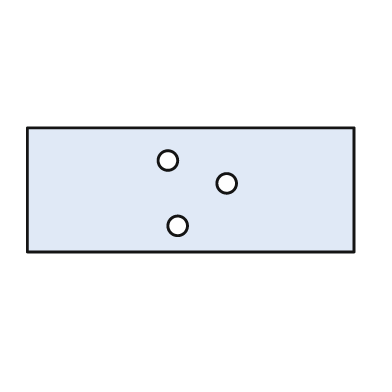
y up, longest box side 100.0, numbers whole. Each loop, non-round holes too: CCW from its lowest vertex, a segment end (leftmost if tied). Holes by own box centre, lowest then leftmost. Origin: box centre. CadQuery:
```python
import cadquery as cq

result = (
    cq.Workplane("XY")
    .moveTo(-50.0, -19.0)
    .lineTo(50.0, -19.0)
    .lineTo(50.0, 19.0)
    .lineTo(-50.0, 19.0)
    .close()
    .moveTo(-4.0, -11.0)
    .circle(3.0)
    .moveTo(11.0, 2.0)
    .circle(3.0)
    .moveTo(-7.0, 9.0)
    .circle(3.0)
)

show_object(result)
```